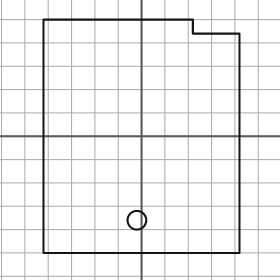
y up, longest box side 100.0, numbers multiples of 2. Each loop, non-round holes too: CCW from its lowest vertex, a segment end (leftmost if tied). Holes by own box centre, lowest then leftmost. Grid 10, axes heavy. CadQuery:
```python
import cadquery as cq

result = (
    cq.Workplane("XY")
    .moveTo(-42.0, -50.0)
    .lineTo(42.0, -50.0)
    .lineTo(42.0, 44.0)
    .lineTo(22.0, 44.0)
    .lineTo(22.0, 50.0)
    .lineTo(-42.0, 50.0)
    .close()
    .moveTo(-2.0, -36.0)
    .circle(4.0)
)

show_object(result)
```